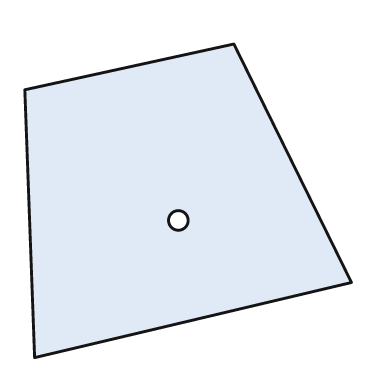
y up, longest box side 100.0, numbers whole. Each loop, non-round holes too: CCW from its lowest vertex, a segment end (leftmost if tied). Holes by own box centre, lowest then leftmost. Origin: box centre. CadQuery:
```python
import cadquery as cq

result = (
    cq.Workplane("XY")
    .moveTo(-47.0, -48.0)
    .lineTo(50.0, -25.0)
    .lineTo(14.0, 48.0)
    .lineTo(-50.0, 34.0)
    .close()
    .moveTo(-3.0, -6.0)
    .circle(3.0)
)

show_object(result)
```